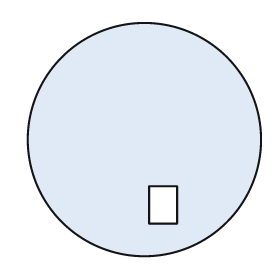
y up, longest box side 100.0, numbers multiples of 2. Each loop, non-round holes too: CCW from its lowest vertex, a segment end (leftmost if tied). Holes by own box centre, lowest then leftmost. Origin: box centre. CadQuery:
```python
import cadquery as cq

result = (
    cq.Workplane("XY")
    .moveTo(0.0, 0.0)
    .circle(50.0)
    .moveTo(2.0, -36.0)
    .lineTo(14.0, -36.0)
    .lineTo(14.0, -20.0)
    .lineTo(2.0, -20.0)
    .close()
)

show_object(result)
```